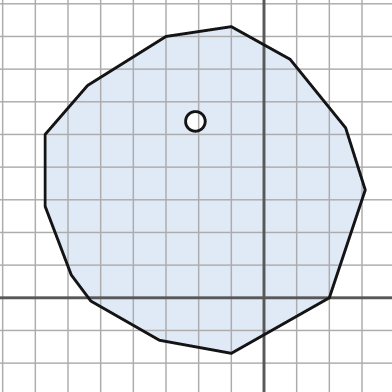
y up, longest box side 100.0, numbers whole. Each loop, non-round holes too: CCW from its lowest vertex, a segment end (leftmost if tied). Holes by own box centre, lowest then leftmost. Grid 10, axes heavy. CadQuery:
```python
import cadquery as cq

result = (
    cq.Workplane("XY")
    .moveTo(-10.0, -17.0)
    .lineTo(20.0, 0.0)
    .lineTo(31.0, 33.0)
    .lineTo(25.0, 52.0)
    .lineTo(8.0, 73.0)
    .lineTo(-10.0, 83.0)
    .lineTo(-30.0, 80.0)
    .lineTo(-54.0, 65.0)
    .lineTo(-67.0, 50.0)
    .lineTo(-67.0, 28.0)
    .lineTo(-59.0, 7.0)
    .lineTo(-53.0, -1.0)
    .lineTo(-32.0, -13.0)
    .close()
    .moveTo(-21.0, 54.0)
    .circle(3.0)
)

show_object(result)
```